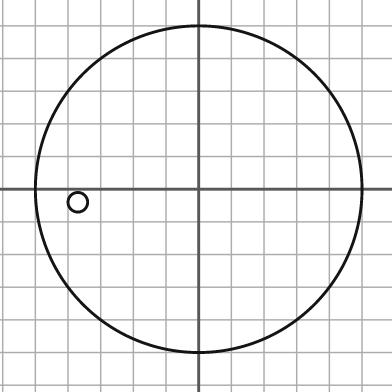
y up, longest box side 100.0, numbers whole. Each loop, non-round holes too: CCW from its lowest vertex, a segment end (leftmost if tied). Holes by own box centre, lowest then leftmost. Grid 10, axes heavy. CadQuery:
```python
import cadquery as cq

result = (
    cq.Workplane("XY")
    .moveTo(0.0, 0.0)
    .circle(50.0)
    .moveTo(-37.0, -4.0)
    .circle(3.0)
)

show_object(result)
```